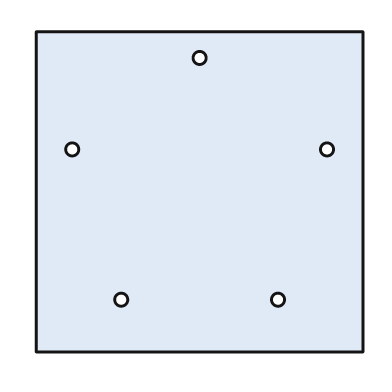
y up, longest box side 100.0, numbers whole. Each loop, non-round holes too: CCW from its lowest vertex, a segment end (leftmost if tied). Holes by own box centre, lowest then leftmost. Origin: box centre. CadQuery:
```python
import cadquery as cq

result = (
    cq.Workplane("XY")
    .moveTo(-50.0, -49.0)
    .lineTo(50.0, -49.0)
    .lineTo(50.0, 49.0)
    .lineTo(-50.0, 49.0)
    .close()
    .moveTo(-24.0, -33.0)
    .circle(2.0)
    .moveTo(24.0, -33.0)
    .circle(2.0)
    .moveTo(-39.0, 13.0)
    .circle(2.0)
    .moveTo(39.0, 13.0)
    .circle(2.0)
    .moveTo(0.0, 41.0)
    .circle(2.0)
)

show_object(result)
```